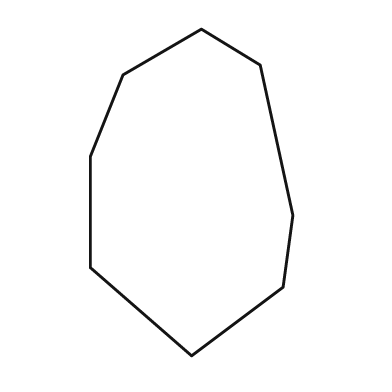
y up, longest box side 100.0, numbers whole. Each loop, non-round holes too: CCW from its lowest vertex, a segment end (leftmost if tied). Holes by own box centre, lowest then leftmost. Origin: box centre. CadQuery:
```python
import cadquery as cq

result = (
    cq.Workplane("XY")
    .moveTo(0.0, -50.0)
    .lineTo(28.0, -29.0)
    .lineTo(31.0, -7.0)
    .lineTo(21.0, 39.0)
    .lineTo(3.0, 50.0)
    .lineTo(-21.0, 36.0)
    .lineTo(-31.0, 11.0)
    .lineTo(-31.0, -23.0)
    .close()
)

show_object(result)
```